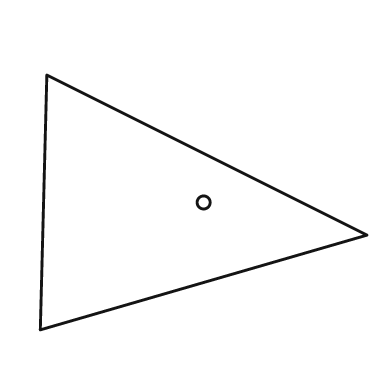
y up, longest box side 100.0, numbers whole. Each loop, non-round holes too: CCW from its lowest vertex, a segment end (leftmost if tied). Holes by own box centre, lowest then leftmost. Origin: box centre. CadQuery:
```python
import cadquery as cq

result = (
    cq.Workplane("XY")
    .moveTo(-50.0, -39.0)
    .lineTo(50.0, -10.0)
    .lineTo(-48.0, 39.0)
    .close()
    .moveTo(0.0, 0.0)
    .circle(2.0)
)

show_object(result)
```